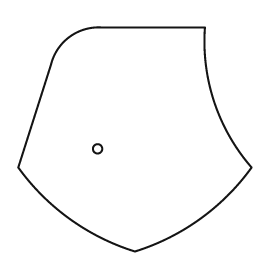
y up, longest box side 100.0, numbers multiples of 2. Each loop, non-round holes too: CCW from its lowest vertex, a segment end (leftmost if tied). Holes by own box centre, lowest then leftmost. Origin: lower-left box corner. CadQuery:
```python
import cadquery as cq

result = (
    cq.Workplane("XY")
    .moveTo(50.0, 0.0)
    .threePointArc((78.0, 14.0), (100.0, 36.0))
    .threePointArc((84.0, 64.0), (80.0, 96.0))
    .lineTo(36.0, 96.0)
    .threePointArc((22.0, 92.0), (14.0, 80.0))
    .lineTo(0.0, 36.0)
    .threePointArc((22.0, 14.0), (50.0, 0.0))
    .close()
    .moveTo(34.0, 44.0)
    .circle(2.0)
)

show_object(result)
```